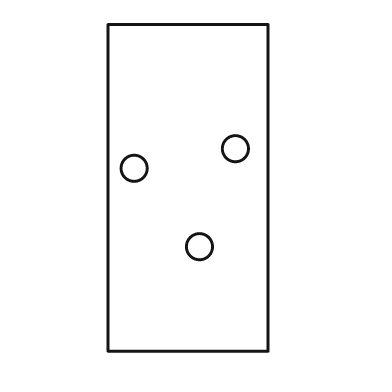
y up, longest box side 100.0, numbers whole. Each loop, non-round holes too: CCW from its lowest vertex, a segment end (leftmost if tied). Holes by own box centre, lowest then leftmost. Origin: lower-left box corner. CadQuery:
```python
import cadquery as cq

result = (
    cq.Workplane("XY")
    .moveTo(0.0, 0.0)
    .lineTo(49.0, 0.0)
    .lineTo(49.0, 100.0)
    .lineTo(0.0, 100.0)
    .close()
    .moveTo(28.0, 32.0)
    .circle(4.0)
    .moveTo(8.0, 56.0)
    .circle(4.0)
    .moveTo(39.0, 62.0)
    .circle(4.0)
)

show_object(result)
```